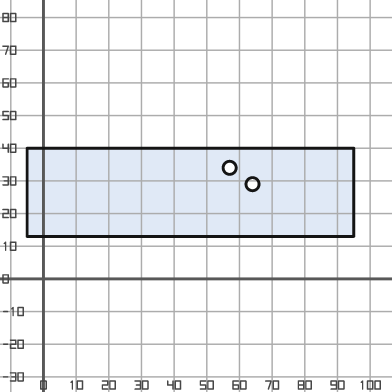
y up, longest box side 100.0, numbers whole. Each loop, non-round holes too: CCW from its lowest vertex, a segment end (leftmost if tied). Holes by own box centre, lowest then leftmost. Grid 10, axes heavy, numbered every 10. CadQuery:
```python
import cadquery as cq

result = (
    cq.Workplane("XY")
    .moveTo(-5.0, 13.0)
    .lineTo(95.0, 13.0)
    .lineTo(95.0, 40.0)
    .lineTo(-5.0, 40.0)
    .close()
    .moveTo(64.0, 29.0)
    .circle(2.0)
    .moveTo(57.0, 34.0)
    .circle(2.0)
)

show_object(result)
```